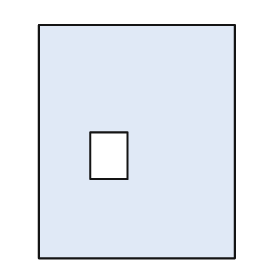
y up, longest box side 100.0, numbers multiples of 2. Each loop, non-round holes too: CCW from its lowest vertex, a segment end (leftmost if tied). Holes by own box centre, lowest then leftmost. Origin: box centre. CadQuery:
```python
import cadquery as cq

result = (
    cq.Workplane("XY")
    .moveTo(-42.0, -50.0)
    .lineTo(42.0, -50.0)
    .lineTo(42.0, 50.0)
    .lineTo(-42.0, 50.0)
    .close()
    .moveTo(-20.0, -16.0)
    .lineTo(-4.0, -16.0)
    .lineTo(-4.0, 4.0)
    .lineTo(-20.0, 4.0)
    .close()
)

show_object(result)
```